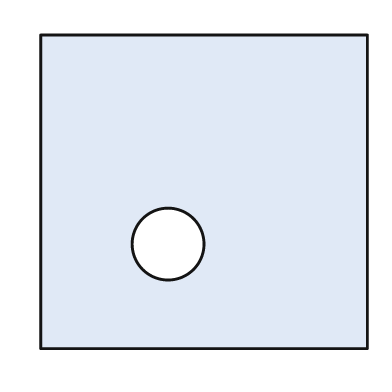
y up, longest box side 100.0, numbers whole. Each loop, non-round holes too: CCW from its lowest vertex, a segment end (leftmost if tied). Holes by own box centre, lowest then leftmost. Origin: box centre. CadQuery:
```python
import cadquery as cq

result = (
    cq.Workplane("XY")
    .moveTo(-50.0, -48.0)
    .lineTo(50.0, -48.0)
    .lineTo(50.0, 48.0)
    .lineTo(-50.0, 48.0)
    .close()
    .moveTo(-11.0, -16.0)
    .circle(11.0)
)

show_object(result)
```